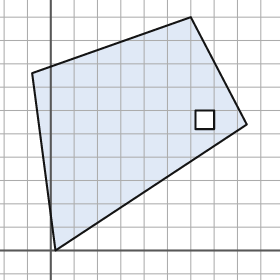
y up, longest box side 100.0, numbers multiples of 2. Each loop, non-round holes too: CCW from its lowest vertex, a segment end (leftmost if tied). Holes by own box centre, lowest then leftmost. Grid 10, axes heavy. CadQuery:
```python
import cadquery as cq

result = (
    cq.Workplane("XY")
    .moveTo(2.0, 0.0)
    .lineTo(84.0, 54.0)
    .lineTo(60.0, 100.0)
    .lineTo(-8.0, 76.0)
    .close()
    .moveTo(62.0, 52.0)
    .lineTo(70.0, 52.0)
    .lineTo(70.0, 60.0)
    .lineTo(62.0, 60.0)
    .close()
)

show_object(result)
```